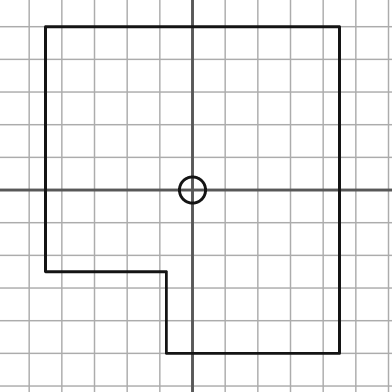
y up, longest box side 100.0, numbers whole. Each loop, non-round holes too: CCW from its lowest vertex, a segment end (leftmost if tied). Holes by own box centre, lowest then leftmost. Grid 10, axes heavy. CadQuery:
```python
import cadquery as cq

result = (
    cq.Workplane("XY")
    .moveTo(-8.0, -50.0)
    .lineTo(45.0, -50.0)
    .lineTo(45.0, 50.0)
    .lineTo(-45.0, 50.0)
    .lineTo(-45.0, -25.0)
    .lineTo(-8.0, -25.0)
    .close()
    .moveTo(0.0, 0.0)
    .circle(4.0)
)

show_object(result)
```